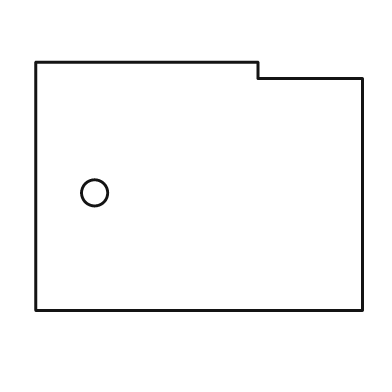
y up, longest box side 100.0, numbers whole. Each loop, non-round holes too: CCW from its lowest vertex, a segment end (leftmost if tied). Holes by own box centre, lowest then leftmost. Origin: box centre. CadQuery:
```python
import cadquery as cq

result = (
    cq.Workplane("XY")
    .moveTo(-50.0, -38.0)
    .lineTo(50.0, -38.0)
    .lineTo(50.0, 33.0)
    .lineTo(18.0, 33.0)
    .lineTo(18.0, 38.0)
    .lineTo(-50.0, 38.0)
    .close()
    .moveTo(-32.0, -2.0)
    .circle(4.0)
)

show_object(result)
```